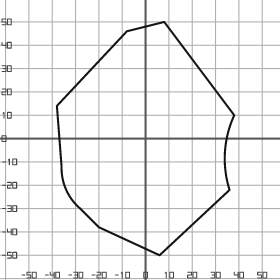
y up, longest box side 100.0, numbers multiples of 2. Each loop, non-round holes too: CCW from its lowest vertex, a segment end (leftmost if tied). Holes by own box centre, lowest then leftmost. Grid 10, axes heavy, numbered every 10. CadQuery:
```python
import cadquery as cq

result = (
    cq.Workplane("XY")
    .moveTo(6.0, -50.0)
    .lineTo(36.0, -22.0)
    .threePointArc((34.0, -6.0), (38.0, 10.0))
    .lineTo(8.0, 50.0)
    .lineTo(-8.0, 46.0)
    .lineTo(-38.0, 14.0)
    .lineTo(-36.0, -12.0)
    .threePointArc((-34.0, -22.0), (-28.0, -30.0))
    .lineTo(-20.0, -38.0)
    .close()
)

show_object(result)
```